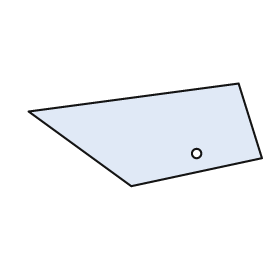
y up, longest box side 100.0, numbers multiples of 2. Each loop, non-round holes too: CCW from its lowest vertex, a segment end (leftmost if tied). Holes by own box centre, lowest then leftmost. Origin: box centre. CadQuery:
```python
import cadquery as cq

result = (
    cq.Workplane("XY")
    .moveTo(-6.0, -22.0)
    .lineTo(50.0, -10.0)
    .lineTo(40.0, 22.0)
    .lineTo(-50.0, 10.0)
    .close()
    .moveTo(22.0, -8.0)
    .circle(2.0)
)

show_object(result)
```